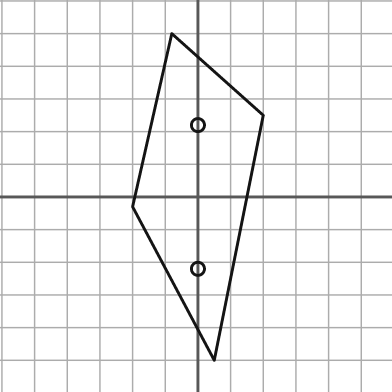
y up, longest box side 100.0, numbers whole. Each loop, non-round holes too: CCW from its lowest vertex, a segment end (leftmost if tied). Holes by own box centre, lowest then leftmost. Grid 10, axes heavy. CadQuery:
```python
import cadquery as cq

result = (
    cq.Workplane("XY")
    .moveTo(5.0, -50.0)
    .lineTo(20.0, 25.0)
    .lineTo(-8.0, 50.0)
    .lineTo(-20.0, -3.0)
    .close()
    .moveTo(0.0, -22.0)
    .circle(2.0)
    .moveTo(0.0, 22.0)
    .circle(2.0)
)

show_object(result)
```